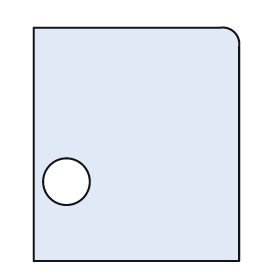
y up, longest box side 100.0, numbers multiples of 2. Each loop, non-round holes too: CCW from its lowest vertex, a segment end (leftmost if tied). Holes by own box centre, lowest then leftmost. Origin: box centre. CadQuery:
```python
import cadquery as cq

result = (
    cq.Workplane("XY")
    .moveTo(-44.0, -50.0)
    .lineTo(44.0, -50.0)
    .lineTo(44.0, 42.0)
    .threePointArc((42.0, 48.0), (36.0, 50.0))
    .lineTo(-44.0, 50.0)
    .close()
    .moveTo(-30.0, -16.0)
    .circle(10.0)
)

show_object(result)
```